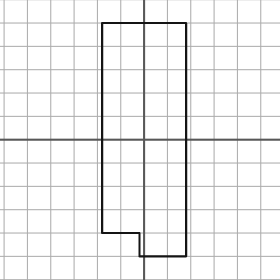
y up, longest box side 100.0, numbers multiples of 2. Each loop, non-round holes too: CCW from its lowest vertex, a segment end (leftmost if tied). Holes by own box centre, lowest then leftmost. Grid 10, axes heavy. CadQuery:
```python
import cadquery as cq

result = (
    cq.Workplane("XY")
    .moveTo(-2.0, -50.0)
    .lineTo(18.0, -50.0)
    .lineTo(18.0, 50.0)
    .lineTo(-18.0, 50.0)
    .lineTo(-18.0, -40.0)
    .lineTo(-2.0, -40.0)
    .close()
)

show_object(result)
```